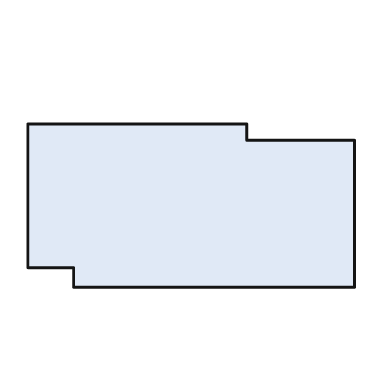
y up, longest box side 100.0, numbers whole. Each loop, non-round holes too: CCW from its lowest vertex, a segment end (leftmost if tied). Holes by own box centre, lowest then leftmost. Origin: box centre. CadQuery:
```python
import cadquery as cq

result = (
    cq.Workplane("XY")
    .moveTo(-36.0, -25.0)
    .lineTo(50.0, -25.0)
    .lineTo(50.0, 20.0)
    .lineTo(17.0, 20.0)
    .lineTo(17.0, 25.0)
    .lineTo(-50.0, 25.0)
    .lineTo(-50.0, -19.0)
    .lineTo(-36.0, -19.0)
    .close()
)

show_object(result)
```